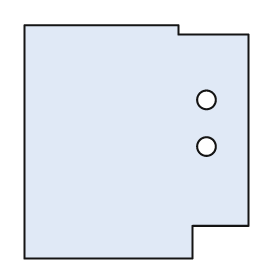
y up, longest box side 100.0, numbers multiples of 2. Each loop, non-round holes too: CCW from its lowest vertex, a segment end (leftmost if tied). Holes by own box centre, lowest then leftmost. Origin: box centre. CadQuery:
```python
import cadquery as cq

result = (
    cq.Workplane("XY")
    .moveTo(-48.0, -50.0)
    .lineTo(24.0, -50.0)
    .lineTo(24.0, -36.0)
    .lineTo(48.0, -36.0)
    .lineTo(48.0, 46.0)
    .lineTo(18.0, 46.0)
    .lineTo(18.0, 50.0)
    .lineTo(-48.0, 50.0)
    .close()
    .moveTo(30.0, -2.0)
    .circle(4.0)
    .moveTo(30.0, 18.0)
    .circle(4.0)
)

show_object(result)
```